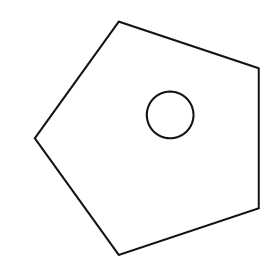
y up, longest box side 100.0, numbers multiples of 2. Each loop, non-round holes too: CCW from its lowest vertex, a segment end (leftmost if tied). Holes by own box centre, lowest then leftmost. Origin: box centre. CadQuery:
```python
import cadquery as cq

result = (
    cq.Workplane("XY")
    .moveTo(-12.0, -50.0)
    .lineTo(48.0, -30.0)
    .lineTo(48.0, 30.0)
    .lineTo(-12.0, 50.0)
    .lineTo(-48.0, 0.0)
    .close()
    .moveTo(10.0, 10.0)
    .circle(10.0)
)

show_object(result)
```